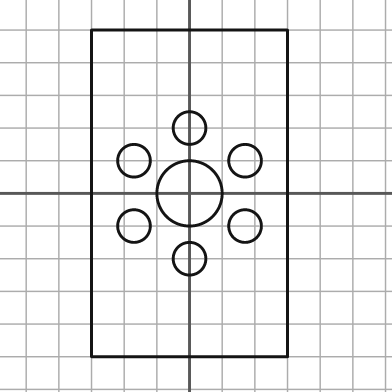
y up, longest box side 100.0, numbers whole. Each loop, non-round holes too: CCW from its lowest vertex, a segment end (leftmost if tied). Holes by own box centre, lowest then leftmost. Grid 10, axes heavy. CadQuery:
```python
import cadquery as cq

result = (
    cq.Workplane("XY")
    .moveTo(-30.0, -50.0)
    .lineTo(30.0, -50.0)
    .lineTo(30.0, 50.0)
    .lineTo(-30.0, 50.0)
    .close()
    .moveTo(0.0, -20.0)
    .circle(5.0)
    .moveTo(-17.0, -10.0)
    .circle(5.0)
    .moveTo(17.0, -10.0)
    .circle(5.0)
    .moveTo(0.0, 0.0)
    .circle(10.0)
    .moveTo(-17.0, 10.0)
    .circle(5.0)
    .moveTo(17.0, 10.0)
    .circle(5.0)
    .moveTo(0.0, 20.0)
    .circle(5.0)
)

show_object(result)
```